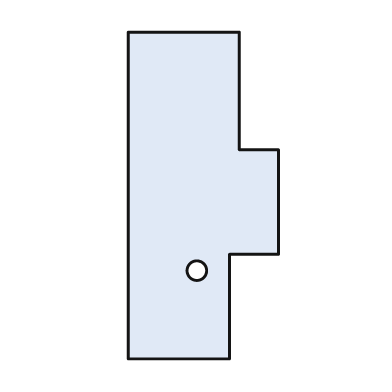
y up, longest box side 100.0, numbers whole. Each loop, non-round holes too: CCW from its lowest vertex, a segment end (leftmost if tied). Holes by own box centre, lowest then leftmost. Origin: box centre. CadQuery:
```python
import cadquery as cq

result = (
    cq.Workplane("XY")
    .moveTo(-23.0, -50.0)
    .lineTo(8.0, -50.0)
    .lineTo(8.0, -18.0)
    .lineTo(23.0, -18.0)
    .lineTo(23.0, 14.0)
    .lineTo(11.0, 14.0)
    .lineTo(11.0, 50.0)
    .lineTo(-23.0, 50.0)
    .close()
    .moveTo(-2.0, -23.0)
    .circle(3.0)
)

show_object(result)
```